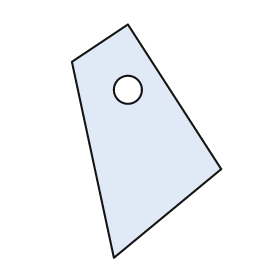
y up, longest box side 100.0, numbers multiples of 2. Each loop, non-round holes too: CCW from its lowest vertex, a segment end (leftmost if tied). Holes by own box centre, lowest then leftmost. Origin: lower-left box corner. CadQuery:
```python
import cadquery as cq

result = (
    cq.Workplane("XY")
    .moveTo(18.0, 0.0)
    .lineTo(64.0, 38.0)
    .lineTo(24.0, 100.0)
    .lineTo(0.0, 84.0)
    .close()
    .moveTo(24.0, 72.0)
    .circle(6.0)
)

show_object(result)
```